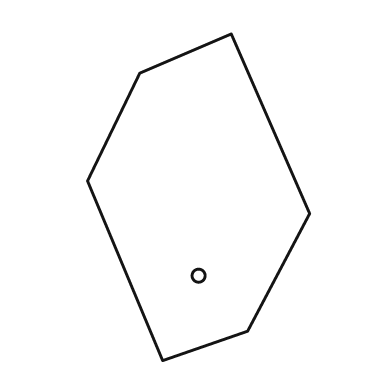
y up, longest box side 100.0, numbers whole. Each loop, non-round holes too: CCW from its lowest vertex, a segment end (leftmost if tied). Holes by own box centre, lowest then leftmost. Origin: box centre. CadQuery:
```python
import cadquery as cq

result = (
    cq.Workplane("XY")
    .moveTo(-11.0, -50.0)
    .lineTo(15.0, -41.0)
    .lineTo(34.0, -5.0)
    .lineTo(10.0, 50.0)
    .lineTo(-18.0, 38.0)
    .lineTo(-34.0, 5.0)
    .close()
    .moveTo(0.0, -24.0)
    .circle(2.0)
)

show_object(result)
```